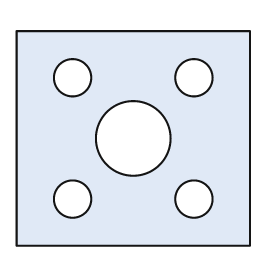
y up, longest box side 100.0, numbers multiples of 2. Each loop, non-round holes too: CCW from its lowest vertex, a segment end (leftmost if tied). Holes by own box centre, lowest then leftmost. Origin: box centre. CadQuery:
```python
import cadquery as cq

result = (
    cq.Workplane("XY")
    .moveTo(-50.0, -46.0)
    .lineTo(50.0, -46.0)
    .lineTo(50.0, 46.0)
    .lineTo(-50.0, 46.0)
    .close()
    .moveTo(-26.0, -26.0)
    .circle(8.0)
    .moveTo(26.0, -26.0)
    .circle(8.0)
    .moveTo(0.0, 0.0)
    .circle(16.0)
    .moveTo(-26.0, 26.0)
    .circle(8.0)
    .moveTo(26.0, 26.0)
    .circle(8.0)
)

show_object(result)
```